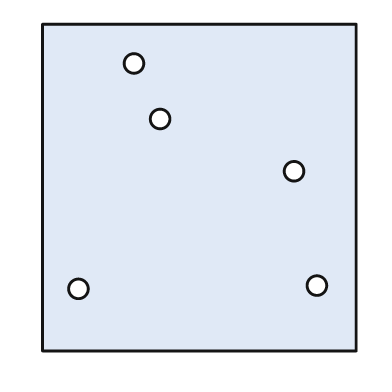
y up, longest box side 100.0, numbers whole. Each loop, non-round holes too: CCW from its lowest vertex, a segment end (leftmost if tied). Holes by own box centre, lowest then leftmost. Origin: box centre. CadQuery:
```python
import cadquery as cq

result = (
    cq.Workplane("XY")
    .moveTo(-48.0, -50.0)
    .lineTo(48.0, -50.0)
    .lineTo(48.0, 50.0)
    .lineTo(-48.0, 50.0)
    .close()
    .moveTo(-37.0, -31.0)
    .circle(3.0)
    .moveTo(36.0, -30.0)
    .circle(3.0)
    .moveTo(29.0, 5.0)
    .circle(3.0)
    .moveTo(-12.0, 21.0)
    .circle(3.0)
    .moveTo(-20.0, 38.0)
    .circle(3.0)
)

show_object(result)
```